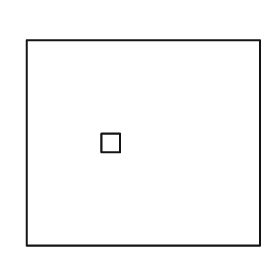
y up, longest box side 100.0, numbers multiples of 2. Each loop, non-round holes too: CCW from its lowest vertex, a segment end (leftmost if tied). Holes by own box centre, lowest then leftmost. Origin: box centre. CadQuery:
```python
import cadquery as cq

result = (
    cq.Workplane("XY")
    .moveTo(-50.0, -44.0)
    .lineTo(50.0, -44.0)
    .lineTo(50.0, 44.0)
    .lineTo(-50.0, 44.0)
    .close()
    .moveTo(-18.0, -4.0)
    .lineTo(-10.0, -4.0)
    .lineTo(-10.0, 4.0)
    .lineTo(-18.0, 4.0)
    .close()
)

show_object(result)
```